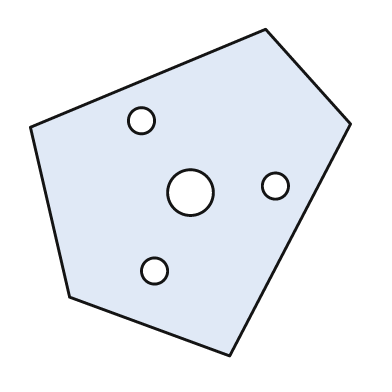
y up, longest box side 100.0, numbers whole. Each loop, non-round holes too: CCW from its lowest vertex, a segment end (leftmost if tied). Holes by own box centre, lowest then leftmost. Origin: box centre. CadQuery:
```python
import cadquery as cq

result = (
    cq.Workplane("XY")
    .moveTo(12.0, -50.0)
    .lineTo(49.0, 21.0)
    .lineTo(23.0, 50.0)
    .lineTo(-49.0, 20.0)
    .lineTo(-37.0, -32.0)
    .close()
    .moveTo(-11.0, -24.0)
    .circle(4.0)
    .moveTo(0.0, 0.0)
    .circle(7.0)
    .moveTo(26.0, 2.0)
    .circle(4.0)
    .moveTo(-15.0, 22.0)
    .circle(4.0)
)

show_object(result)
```